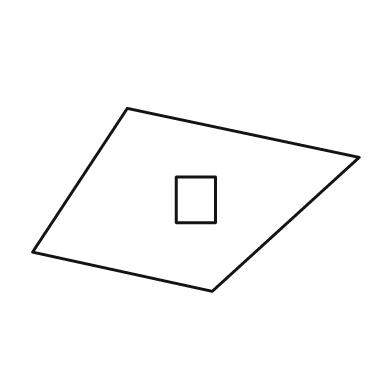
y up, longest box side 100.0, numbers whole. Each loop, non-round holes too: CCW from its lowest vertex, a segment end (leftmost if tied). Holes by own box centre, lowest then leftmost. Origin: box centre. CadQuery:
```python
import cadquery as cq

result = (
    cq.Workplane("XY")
    .moveTo(5.0, -28.0)
    .lineTo(50.0, 13.0)
    .lineTo(-21.0, 28.0)
    .lineTo(-50.0, -16.0)
    .close()
    .moveTo(-6.0, -7.0)
    .lineTo(6.0, -7.0)
    .lineTo(6.0, 7.0)
    .lineTo(-6.0, 7.0)
    .close()
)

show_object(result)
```